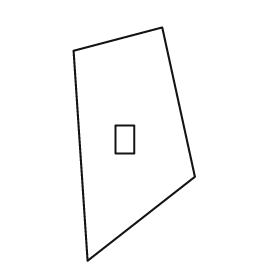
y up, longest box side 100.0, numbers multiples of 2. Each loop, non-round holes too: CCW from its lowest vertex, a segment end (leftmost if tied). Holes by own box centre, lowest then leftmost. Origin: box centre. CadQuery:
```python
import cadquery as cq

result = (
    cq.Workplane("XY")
    .moveTo(-20.0, -50.0)
    .lineTo(26.0, -14.0)
    .lineTo(12.0, 50.0)
    .lineTo(-26.0, 40.0)
    .close()
    .moveTo(-8.0, -4.0)
    .lineTo(0.0, -4.0)
    .lineTo(0.0, 8.0)
    .lineTo(-8.0, 8.0)
    .close()
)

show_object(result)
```